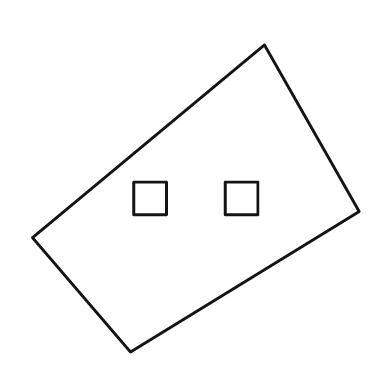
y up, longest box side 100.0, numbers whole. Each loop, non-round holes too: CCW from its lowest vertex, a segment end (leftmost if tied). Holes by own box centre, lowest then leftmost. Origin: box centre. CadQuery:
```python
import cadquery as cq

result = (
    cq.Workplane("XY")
    .moveTo(-20.0, -47.0)
    .lineTo(50.0, -4.0)
    .lineTo(21.0, 47.0)
    .lineTo(-50.0, -12.0)
    .close()
    .moveTo(-19.0, -5.0)
    .lineTo(-9.0, -5.0)
    .lineTo(-9.0, 5.0)
    .lineTo(-19.0, 5.0)
    .close()
    .moveTo(9.0, -5.0)
    .lineTo(19.0, -5.0)
    .lineTo(19.0, 5.0)
    .lineTo(9.0, 5.0)
    .close()
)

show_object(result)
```